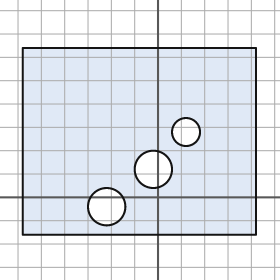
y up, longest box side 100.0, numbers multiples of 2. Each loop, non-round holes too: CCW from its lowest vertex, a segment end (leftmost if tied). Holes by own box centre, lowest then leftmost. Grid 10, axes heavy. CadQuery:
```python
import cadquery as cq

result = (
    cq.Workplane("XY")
    .moveTo(-58.0, -16.0)
    .lineTo(42.0, -16.0)
    .lineTo(42.0, 64.0)
    .lineTo(-58.0, 64.0)
    .close()
    .moveTo(-22.0, -4.0)
    .circle(8.0)
    .moveTo(-2.0, 12.0)
    .circle(8.0)
    .moveTo(12.0, 28.0)
    .circle(6.0)
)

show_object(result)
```